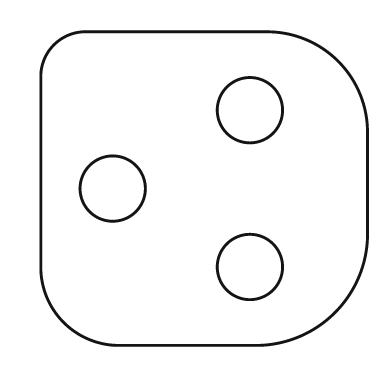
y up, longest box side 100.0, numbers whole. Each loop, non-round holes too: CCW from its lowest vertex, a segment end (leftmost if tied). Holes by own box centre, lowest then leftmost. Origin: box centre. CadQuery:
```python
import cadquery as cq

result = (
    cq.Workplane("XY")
    .moveTo(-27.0, -48.0)
    .lineTo(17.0, -48.0)
    .threePointArc((40.0, -38.0), (50.0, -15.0))
    .lineTo(50.0, 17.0)
    .threePointArc((41.0, 39.0), (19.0, 48.0))
    .lineTo(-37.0, 48.0)
    .threePointArc((-46.0, 44.0), (-50.0, 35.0))
    .lineTo(-50.0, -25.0)
    .threePointArc((-43.0, -41.0), (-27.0, -48.0))
    .close()
    .moveTo(14.0, -24.0)
    .circle(10.0)
    .moveTo(-28.0, 0.0)
    .circle(10.0)
    .moveTo(14.0, 24.0)
    .circle(10.0)
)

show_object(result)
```